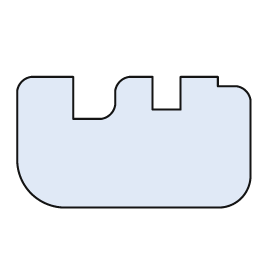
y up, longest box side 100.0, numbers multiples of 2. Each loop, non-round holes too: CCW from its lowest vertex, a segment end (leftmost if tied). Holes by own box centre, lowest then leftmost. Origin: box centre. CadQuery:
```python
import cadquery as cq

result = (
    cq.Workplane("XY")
    .moveTo(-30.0, -28.0)
    .lineTo(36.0, -28.0)
    .threePointArc((46.0, -24.0), (50.0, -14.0))
    .lineTo(50.0, 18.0)
    .threePointArc((48.0, 22.0), (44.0, 24.0))
    .lineTo(36.0, 24.0)
    .lineTo(36.0, 28.0)
    .lineTo(20.0, 28.0)
    .lineTo(20.0, 14.0)
    .lineTo(8.0, 14.0)
    .lineTo(8.0, 28.0)
    .lineTo(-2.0, 28.0)
    .threePointArc((-6.0, 26.0), (-8.0, 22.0))
    .lineTo(-8.0, 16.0)
    .threePointArc((-10.0, 12.0), (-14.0, 10.0))
    .lineTo(-26.0, 10.0)
    .lineTo(-26.0, 28.0)
    .lineTo(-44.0, 28.0)
    .threePointArc((-48.0, 26.0), (-50.0, 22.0))
    .lineTo(-50.0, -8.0)
    .threePointArc((-44.0, -22.0), (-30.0, -28.0))
    .close()
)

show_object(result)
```